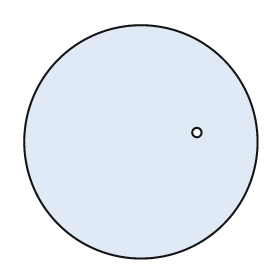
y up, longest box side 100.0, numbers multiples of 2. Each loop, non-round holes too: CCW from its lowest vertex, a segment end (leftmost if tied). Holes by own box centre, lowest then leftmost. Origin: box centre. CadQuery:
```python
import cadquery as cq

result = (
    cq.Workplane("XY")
    .moveTo(0.0, 0.0)
    .circle(50.0)
    .moveTo(24.0, 4.0)
    .circle(2.0)
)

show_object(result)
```